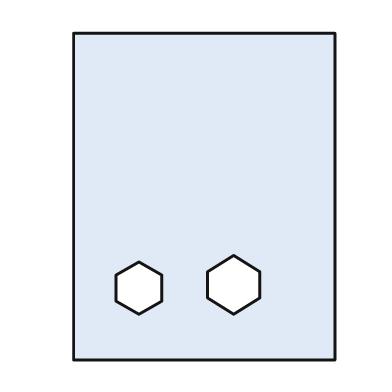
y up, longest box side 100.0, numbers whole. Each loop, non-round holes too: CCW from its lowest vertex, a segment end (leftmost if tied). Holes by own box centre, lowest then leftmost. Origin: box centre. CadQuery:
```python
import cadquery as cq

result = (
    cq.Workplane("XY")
    .moveTo(-40.0, -50.0)
    .lineTo(40.0, -50.0)
    .lineTo(40.0, 50.0)
    .lineTo(-40.0, 50.0)
    .close()
    .moveTo(-20.0, -36.0)
    .lineTo(-13.0, -32.0)
    .lineTo(-13.0, -24.0)
    .lineTo(-20.0, -20.0)
    .lineTo(-27.0, -24.0)
    .lineTo(-27.0, -32.0)
    .close()
    .moveTo(9.0, -36.0)
    .lineTo(17.0, -31.0)
    .lineTo(17.0, -23.0)
    .lineTo(9.0, -18.0)
    .lineTo(1.0, -23.0)
    .lineTo(1.0, -31.0)
    .close()
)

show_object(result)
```